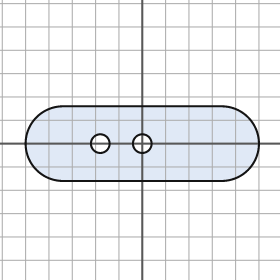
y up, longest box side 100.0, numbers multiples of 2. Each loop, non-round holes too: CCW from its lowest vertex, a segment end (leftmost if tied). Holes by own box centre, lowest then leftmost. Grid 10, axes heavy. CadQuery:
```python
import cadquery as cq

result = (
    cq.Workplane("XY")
    .moveTo(-34.0, -16.0)
    .lineTo(34.0, -16.0)
    .threePointArc((50.0, 0.0), (34.0, 16.0))
    .lineTo(-34.0, 16.0)
    .threePointArc((-50.0, 0.0), (-34.0, -16.0))
    .close()
    .moveTo(-18.0, 0.0)
    .circle(4.0)
    .moveTo(0.0, 0.0)
    .circle(4.0)
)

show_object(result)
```